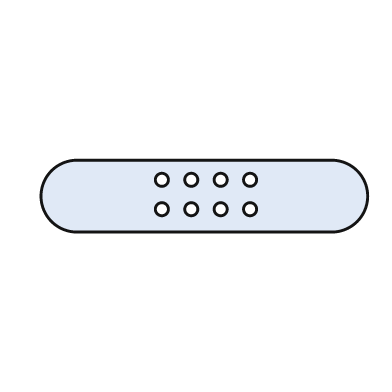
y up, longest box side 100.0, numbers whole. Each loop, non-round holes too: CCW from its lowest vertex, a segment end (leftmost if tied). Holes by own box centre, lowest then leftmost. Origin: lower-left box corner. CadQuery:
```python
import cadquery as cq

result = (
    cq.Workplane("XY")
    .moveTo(11.0, 0.0)
    .lineTo(89.0, 0.0)
    .threePointArc((100.0, 11.0), (89.0, 22.0))
    .lineTo(11.0, 22.0)
    .threePointArc((0.0, 11.0), (11.0, 0.0))
    .close()
    .moveTo(37.0, 7.0)
    .circle(2.0)
    .moveTo(46.0, 7.0)
    .circle(2.0)
    .moveTo(55.0, 7.0)
    .circle(2.0)
    .moveTo(64.0, 7.0)
    .circle(2.0)
    .moveTo(37.0, 16.0)
    .circle(2.0)
    .moveTo(46.0, 16.0)
    .circle(2.0)
    .moveTo(55.0, 16.0)
    .circle(2.0)
    .moveTo(64.0, 16.0)
    .circle(2.0)
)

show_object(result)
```